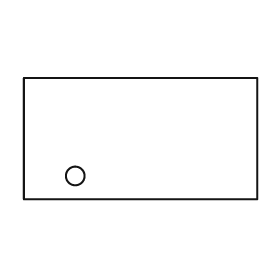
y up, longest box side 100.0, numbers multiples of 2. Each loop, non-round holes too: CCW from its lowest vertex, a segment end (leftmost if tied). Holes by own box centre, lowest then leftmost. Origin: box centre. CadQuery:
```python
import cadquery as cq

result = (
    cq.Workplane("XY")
    .moveTo(-50.0, -26.0)
    .lineTo(50.0, -26.0)
    .lineTo(50.0, 26.0)
    .lineTo(-50.0, 26.0)
    .close()
    .moveTo(-28.0, -16.0)
    .circle(4.0)
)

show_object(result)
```